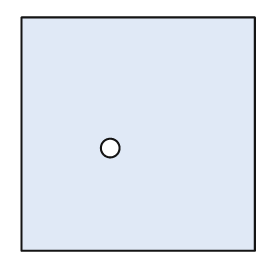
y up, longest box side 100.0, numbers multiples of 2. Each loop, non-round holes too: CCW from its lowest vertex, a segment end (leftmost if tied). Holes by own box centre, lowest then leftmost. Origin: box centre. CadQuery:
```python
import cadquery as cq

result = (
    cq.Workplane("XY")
    .moveTo(-50.0, -50.0)
    .lineTo(50.0, -50.0)
    .lineTo(50.0, 50.0)
    .lineTo(-50.0, 50.0)
    .close()
    .moveTo(-12.0, -6.0)
    .circle(4.0)
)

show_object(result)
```